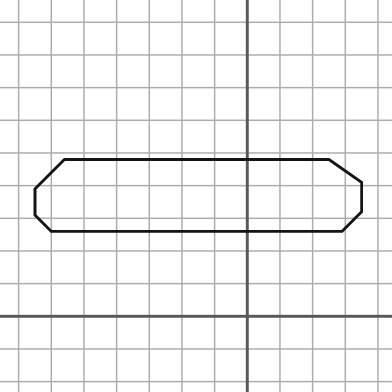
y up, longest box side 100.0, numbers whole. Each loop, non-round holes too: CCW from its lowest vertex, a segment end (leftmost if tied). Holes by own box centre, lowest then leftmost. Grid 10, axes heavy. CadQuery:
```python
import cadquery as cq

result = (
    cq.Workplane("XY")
    .moveTo(-60.0, 26.0)
    .lineTo(29.0, 26.0)
    .lineTo(35.0, 32.0)
    .lineTo(35.0, 41.0)
    .lineTo(25.0, 48.0)
    .lineTo(-56.0, 48.0)
    .lineTo(-65.0, 39.0)
    .lineTo(-65.0, 31.0)
    .close()
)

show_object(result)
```